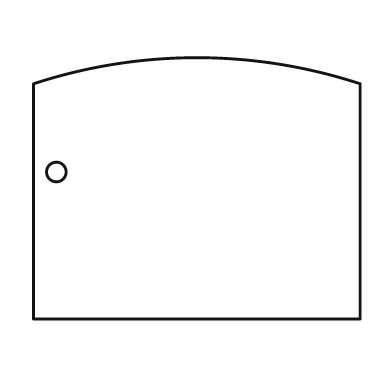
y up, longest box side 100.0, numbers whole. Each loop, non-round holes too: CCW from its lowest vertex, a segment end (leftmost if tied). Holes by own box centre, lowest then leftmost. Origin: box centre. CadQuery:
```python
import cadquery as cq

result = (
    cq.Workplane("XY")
    .moveTo(-50.0, -40.0)
    .lineTo(50.0, -40.0)
    .lineTo(50.0, 32.0)
    .threePointArc((0.0, 40.0), (-50.0, 32.0))
    .close()
    .moveTo(-43.0, 5.0)
    .circle(3.0)
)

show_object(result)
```